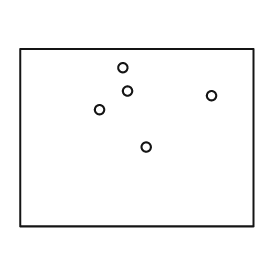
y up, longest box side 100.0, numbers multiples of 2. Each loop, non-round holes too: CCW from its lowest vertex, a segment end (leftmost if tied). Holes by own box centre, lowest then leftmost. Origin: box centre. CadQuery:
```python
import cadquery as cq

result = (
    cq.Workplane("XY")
    .moveTo(-50.0, -38.0)
    .lineTo(50.0, -38.0)
    .lineTo(50.0, 38.0)
    .lineTo(-50.0, 38.0)
    .close()
    .moveTo(4.0, -4.0)
    .circle(2.0)
    .moveTo(-16.0, 12.0)
    .circle(2.0)
    .moveTo(32.0, 18.0)
    .circle(2.0)
    .moveTo(-4.0, 20.0)
    .circle(2.0)
    .moveTo(-6.0, 30.0)
    .circle(2.0)
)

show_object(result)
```